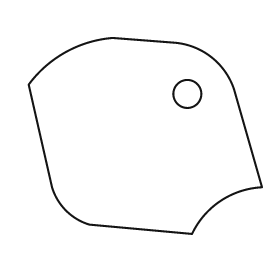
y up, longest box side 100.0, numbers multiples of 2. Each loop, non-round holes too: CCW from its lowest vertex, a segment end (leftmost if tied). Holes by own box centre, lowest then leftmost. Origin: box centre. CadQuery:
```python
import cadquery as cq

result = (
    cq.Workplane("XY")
    .moveTo(20.0, -42.0)
    .threePointArc((32.0, -28.0), (50.0, -22.0))
    .lineTo(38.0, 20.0)
    .threePointArc((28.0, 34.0), (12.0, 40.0))
    .lineTo(-14.0, 42.0)
    .threePointArc((-34.0, 36.0), (-50.0, 22.0))
    .lineTo(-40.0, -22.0)
    .threePointArc((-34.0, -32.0), (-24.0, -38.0))
    .close()
    .moveTo(18.0, 18.0)
    .circle(6.0)
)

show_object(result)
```